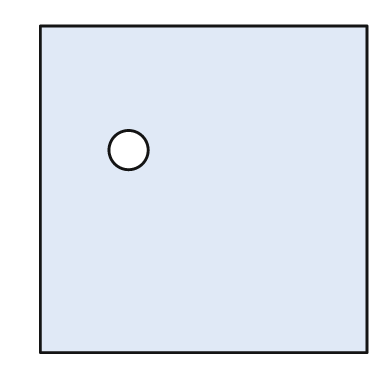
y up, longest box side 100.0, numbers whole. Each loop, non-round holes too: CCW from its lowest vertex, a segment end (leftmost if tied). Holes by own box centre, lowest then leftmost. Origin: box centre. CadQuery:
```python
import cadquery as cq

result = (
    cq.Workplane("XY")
    .moveTo(-50.0, -50.0)
    .lineTo(50.0, -50.0)
    .lineTo(50.0, 50.0)
    .lineTo(-50.0, 50.0)
    .close()
    .moveTo(-23.0, 12.0)
    .circle(6.0)
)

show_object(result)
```